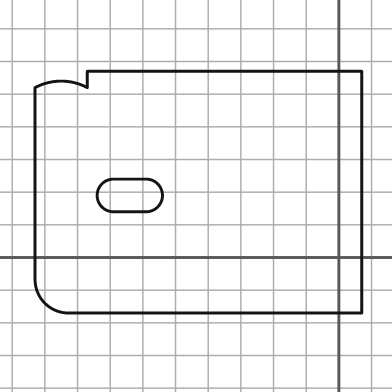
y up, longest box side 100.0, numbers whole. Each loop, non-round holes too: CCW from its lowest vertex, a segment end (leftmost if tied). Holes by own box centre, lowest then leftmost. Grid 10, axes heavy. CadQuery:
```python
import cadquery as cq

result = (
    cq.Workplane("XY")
    .moveTo(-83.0, -17.0)
    .lineTo(7.0, -17.0)
    .lineTo(7.0, 57.0)
    .lineTo(-77.0, 57.0)
    .lineTo(-77.0, 52.0)
    .threePointArc((-85.0, 54.0), (-93.0, 52.0))
    .lineTo(-93.0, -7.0)
    .threePointArc((-90.0, -14.0), (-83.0, -17.0))
    .close()
    .moveTo(-69.0, 14.0)
    .lineTo(-59.0, 14.0)
    .threePointArc((-54.0, 19.0), (-59.0, 24.0))
    .lineTo(-69.0, 24.0)
    .threePointArc((-74.0, 19.0), (-69.0, 14.0))
    .close()
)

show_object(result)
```